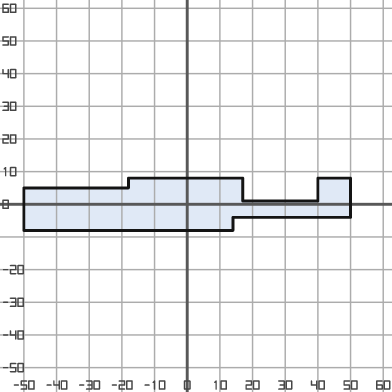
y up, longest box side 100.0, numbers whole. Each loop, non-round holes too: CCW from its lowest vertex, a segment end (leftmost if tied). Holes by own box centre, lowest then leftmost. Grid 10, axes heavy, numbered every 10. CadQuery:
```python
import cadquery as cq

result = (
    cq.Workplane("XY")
    .moveTo(-50.0, -8.0)
    .lineTo(14.0, -8.0)
    .lineTo(14.0, -4.0)
    .lineTo(50.0, -4.0)
    .lineTo(50.0, 8.0)
    .lineTo(40.0, 8.0)
    .lineTo(40.0, 1.0)
    .lineTo(17.0, 1.0)
    .lineTo(17.0, 8.0)
    .lineTo(-18.0, 8.0)
    .lineTo(-18.0, 5.0)
    .lineTo(-50.0, 5.0)
    .close()
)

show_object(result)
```